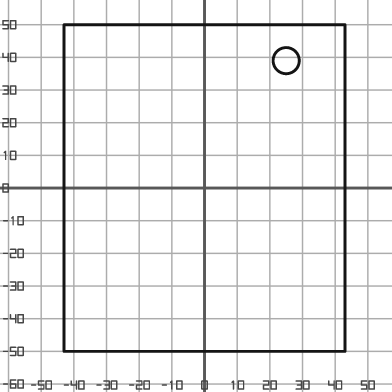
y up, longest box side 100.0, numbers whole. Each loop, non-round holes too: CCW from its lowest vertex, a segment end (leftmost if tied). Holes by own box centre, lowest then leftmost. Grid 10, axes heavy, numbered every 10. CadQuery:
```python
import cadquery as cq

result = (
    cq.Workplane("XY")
    .moveTo(-43.0, -50.0)
    .lineTo(43.0, -50.0)
    .lineTo(43.0, 50.0)
    .lineTo(-43.0, 50.0)
    .close()
    .moveTo(25.0, 39.0)
    .circle(4.0)
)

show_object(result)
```